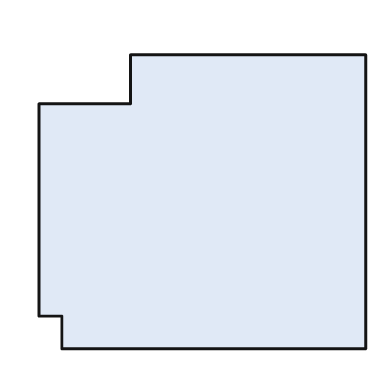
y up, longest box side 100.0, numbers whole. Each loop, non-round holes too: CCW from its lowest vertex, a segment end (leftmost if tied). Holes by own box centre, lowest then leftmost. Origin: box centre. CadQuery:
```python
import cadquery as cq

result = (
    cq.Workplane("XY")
    .moveTo(-43.0, -45.0)
    .lineTo(50.0, -45.0)
    .lineTo(50.0, 45.0)
    .lineTo(-22.0, 45.0)
    .lineTo(-22.0, 30.0)
    .lineTo(-50.0, 30.0)
    .lineTo(-50.0, -35.0)
    .lineTo(-43.0, -35.0)
    .close()
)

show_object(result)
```